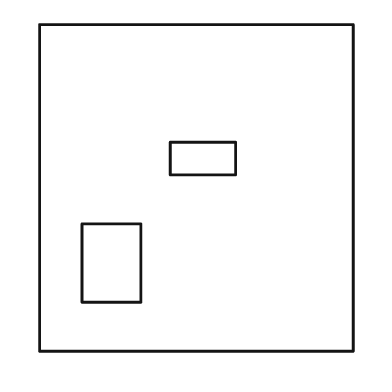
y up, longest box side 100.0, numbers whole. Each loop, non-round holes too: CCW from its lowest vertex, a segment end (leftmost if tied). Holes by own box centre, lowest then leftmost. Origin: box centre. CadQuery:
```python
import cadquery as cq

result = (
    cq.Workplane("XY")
    .moveTo(-48.0, -50.0)
    .lineTo(48.0, -50.0)
    .lineTo(48.0, 50.0)
    .lineTo(-48.0, 50.0)
    .close()
    .moveTo(-35.0, -35.0)
    .lineTo(-17.0, -35.0)
    .lineTo(-17.0, -11.0)
    .lineTo(-35.0, -11.0)
    .close()
    .moveTo(-8.0, 4.0)
    .lineTo(12.0, 4.0)
    .lineTo(12.0, 14.0)
    .lineTo(-8.0, 14.0)
    .close()
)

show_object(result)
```